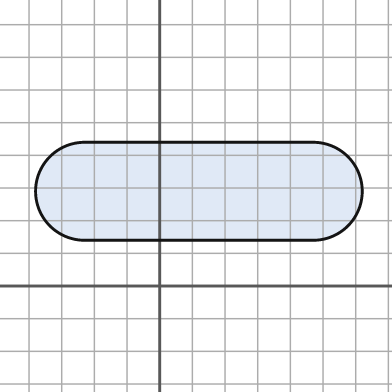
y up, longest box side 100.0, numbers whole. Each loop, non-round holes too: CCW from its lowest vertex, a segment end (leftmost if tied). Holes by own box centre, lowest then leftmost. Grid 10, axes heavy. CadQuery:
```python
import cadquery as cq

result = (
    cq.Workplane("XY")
    .moveTo(-23.0, 14.0)
    .lineTo(47.0, 14.0)
    .threePointArc((62.0, 29.0), (47.0, 44.0))
    .lineTo(-23.0, 44.0)
    .threePointArc((-38.0, 29.0), (-23.0, 14.0))
    .close()
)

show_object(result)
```